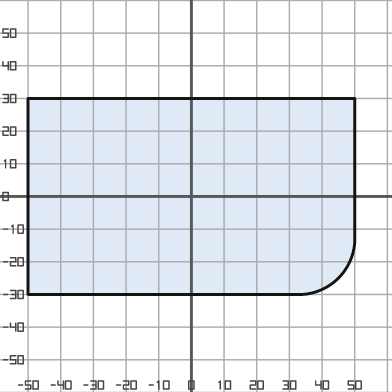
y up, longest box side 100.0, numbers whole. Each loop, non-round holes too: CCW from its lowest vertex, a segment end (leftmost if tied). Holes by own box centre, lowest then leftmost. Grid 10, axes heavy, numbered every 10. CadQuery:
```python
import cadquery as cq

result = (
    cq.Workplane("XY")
    .moveTo(-50.0, -30.0)
    .lineTo(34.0, -30.0)
    .threePointArc((45.0, -25.0), (50.0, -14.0))
    .lineTo(50.0, 30.0)
    .lineTo(-50.0, 30.0)
    .close()
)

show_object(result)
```